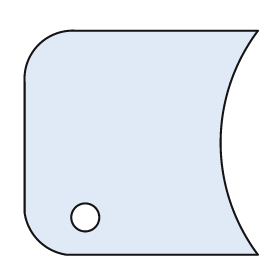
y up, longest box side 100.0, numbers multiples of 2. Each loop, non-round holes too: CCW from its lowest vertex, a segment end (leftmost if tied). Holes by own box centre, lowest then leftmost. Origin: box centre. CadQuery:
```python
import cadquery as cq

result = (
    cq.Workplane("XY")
    .moveTo(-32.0, -48.0)
    .lineTo(50.0, -48.0)
    .threePointArc((34.0, 0.0), (50.0, 48.0))
    .lineTo(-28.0, 48.0)
    .threePointArc((-44.0, 42.0), (-50.0, 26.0))
    .lineTo(-50.0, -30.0)
    .threePointArc((-44.0, -42.0), (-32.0, -48.0))
    .close()
    .moveTo(-24.0, -32.0)
    .circle(6.0)
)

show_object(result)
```